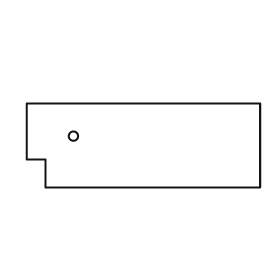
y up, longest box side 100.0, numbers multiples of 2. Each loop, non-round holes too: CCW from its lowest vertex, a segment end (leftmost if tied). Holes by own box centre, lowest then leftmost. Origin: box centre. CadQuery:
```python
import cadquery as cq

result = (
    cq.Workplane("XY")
    .moveTo(-42.0, -18.0)
    .lineTo(50.0, -18.0)
    .lineTo(50.0, 18.0)
    .lineTo(-50.0, 18.0)
    .lineTo(-50.0, -6.0)
    .lineTo(-42.0, -6.0)
    .close()
    .moveTo(-30.0, 4.0)
    .circle(2.0)
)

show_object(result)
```